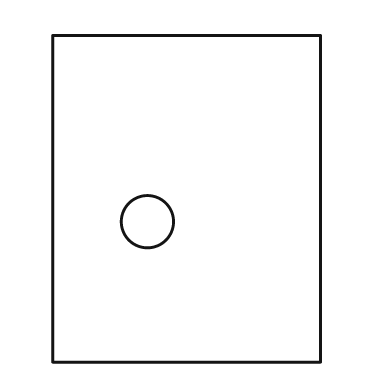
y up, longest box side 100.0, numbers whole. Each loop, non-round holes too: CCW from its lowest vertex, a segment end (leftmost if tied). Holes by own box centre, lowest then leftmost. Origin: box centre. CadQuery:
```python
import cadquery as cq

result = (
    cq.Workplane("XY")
    .moveTo(-41.0, -50.0)
    .lineTo(41.0, -50.0)
    .lineTo(41.0, 50.0)
    .lineTo(-41.0, 50.0)
    .close()
    .moveTo(-12.0, -7.0)
    .circle(8.0)
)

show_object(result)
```